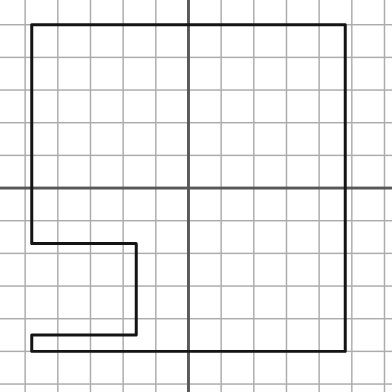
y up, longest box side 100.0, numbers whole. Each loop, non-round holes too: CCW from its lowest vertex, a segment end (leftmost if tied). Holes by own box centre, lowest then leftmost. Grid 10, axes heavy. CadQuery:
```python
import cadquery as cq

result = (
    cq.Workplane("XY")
    .moveTo(-48.0, -50.0)
    .lineTo(48.0, -50.0)
    .lineTo(48.0, 50.0)
    .lineTo(-48.0, 50.0)
    .lineTo(-48.0, -17.0)
    .lineTo(-16.0, -17.0)
    .lineTo(-16.0, -45.0)
    .lineTo(-48.0, -45.0)
    .close()
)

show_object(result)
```